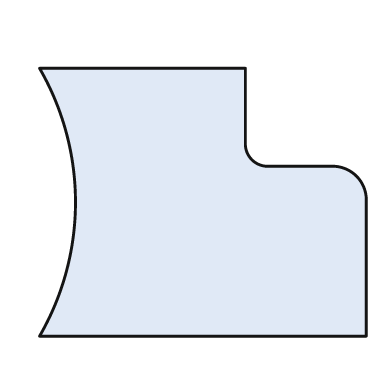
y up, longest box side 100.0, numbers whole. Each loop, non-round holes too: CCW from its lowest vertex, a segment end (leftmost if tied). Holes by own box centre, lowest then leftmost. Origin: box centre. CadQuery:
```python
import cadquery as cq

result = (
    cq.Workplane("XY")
    .moveTo(-50.0, -41.0)
    .lineTo(50.0, -41.0)
    .lineTo(50.0, 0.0)
    .threePointArc((47.0, 8.0), (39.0, 11.0))
    .lineTo(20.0, 11.0)
    .threePointArc((15.0, 13.0), (13.0, 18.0))
    .lineTo(13.0, 41.0)
    .lineTo(-50.0, 41.0)
    .threePointArc((-39.0, 0.0), (-50.0, -41.0))
    .close()
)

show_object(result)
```